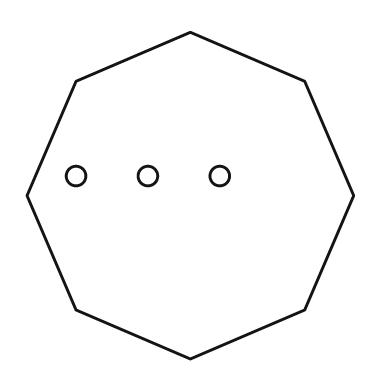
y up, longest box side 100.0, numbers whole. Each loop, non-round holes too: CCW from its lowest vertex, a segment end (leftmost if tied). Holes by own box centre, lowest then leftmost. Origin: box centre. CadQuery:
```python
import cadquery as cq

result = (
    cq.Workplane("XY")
    .moveTo(0.0, -50.0)
    .lineTo(35.0, -35.0)
    .lineTo(50.0, 0.0)
    .lineTo(35.0, 35.0)
    .lineTo(0.0, 50.0)
    .lineTo(-35.0, 35.0)
    .lineTo(-50.0, 0.0)
    .lineTo(-35.0, -35.0)
    .close()
    .moveTo(-35.0, 6.0)
    .circle(3.0)
    .moveTo(-13.0, 6.0)
    .circle(3.0)
    .moveTo(9.0, 6.0)
    .circle(3.0)
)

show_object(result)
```